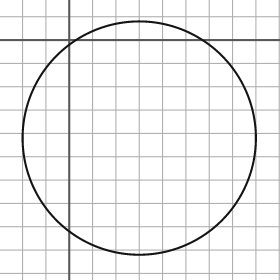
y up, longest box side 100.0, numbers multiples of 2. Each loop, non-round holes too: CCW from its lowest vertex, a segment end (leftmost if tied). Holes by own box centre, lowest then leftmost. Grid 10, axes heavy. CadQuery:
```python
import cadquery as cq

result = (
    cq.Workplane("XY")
    .moveTo(30.0, -42.0)
    .circle(50.0)
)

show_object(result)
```